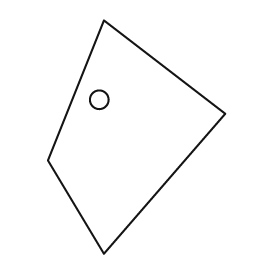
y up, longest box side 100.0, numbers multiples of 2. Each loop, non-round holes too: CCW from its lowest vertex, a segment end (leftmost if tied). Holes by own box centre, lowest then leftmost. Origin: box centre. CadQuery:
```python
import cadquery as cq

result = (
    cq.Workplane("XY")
    .moveTo(-14.0, -50.0)
    .lineTo(38.0, 10.0)
    .lineTo(-14.0, 50.0)
    .lineTo(-38.0, -10.0)
    .close()
    .moveTo(-16.0, 16.0)
    .circle(4.0)
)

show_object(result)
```